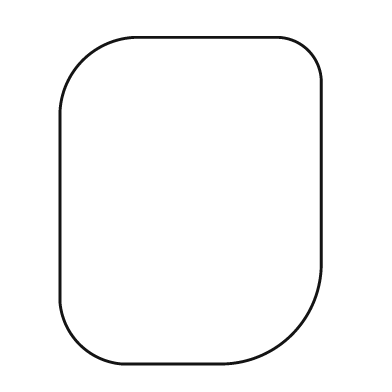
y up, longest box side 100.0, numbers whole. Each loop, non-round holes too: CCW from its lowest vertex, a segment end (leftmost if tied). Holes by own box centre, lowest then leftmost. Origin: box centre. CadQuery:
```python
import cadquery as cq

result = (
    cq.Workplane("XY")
    .moveTo(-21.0, -50.0)
    .lineTo(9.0, -50.0)
    .threePointArc((31.0, -41.0), (40.0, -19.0))
    .lineTo(40.0, 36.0)
    .threePointArc((36.0, 46.0), (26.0, 50.0))
    .lineTo(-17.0, 50.0)
    .threePointArc((-33.0, 43.0), (-40.0, 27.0))
    .lineTo(-40.0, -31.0)
    .threePointArc((-34.0, -44.0), (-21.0, -50.0))
    .close()
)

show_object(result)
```